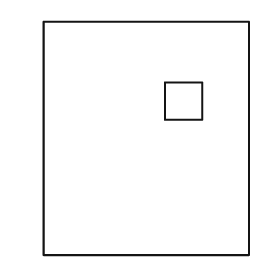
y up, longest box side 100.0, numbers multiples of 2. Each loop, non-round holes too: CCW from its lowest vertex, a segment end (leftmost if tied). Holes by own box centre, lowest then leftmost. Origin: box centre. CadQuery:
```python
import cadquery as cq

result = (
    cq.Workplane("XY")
    .moveTo(-44.0, -50.0)
    .lineTo(44.0, -50.0)
    .lineTo(44.0, 50.0)
    .lineTo(-44.0, 50.0)
    .close()
    .moveTo(8.0, 8.0)
    .lineTo(24.0, 8.0)
    .lineTo(24.0, 24.0)
    .lineTo(8.0, 24.0)
    .close()
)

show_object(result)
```